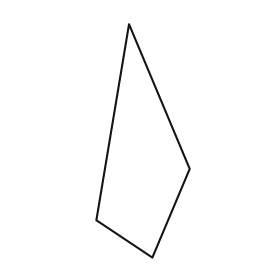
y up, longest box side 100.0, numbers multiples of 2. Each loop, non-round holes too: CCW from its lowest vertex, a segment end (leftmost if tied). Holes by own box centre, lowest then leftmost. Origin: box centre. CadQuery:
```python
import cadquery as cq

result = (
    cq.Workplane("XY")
    .moveTo(4.0, -50.0)
    .lineTo(20.0, -12.0)
    .lineTo(-6.0, 50.0)
    .lineTo(-20.0, -34.0)
    .close()
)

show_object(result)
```